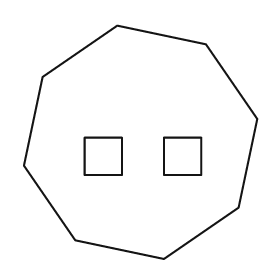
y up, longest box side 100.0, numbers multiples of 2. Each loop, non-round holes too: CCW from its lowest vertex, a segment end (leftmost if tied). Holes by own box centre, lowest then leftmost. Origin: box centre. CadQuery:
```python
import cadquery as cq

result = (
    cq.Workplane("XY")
    .moveTo(10.0, -50.0)
    .lineTo(42.0, -28.0)
    .lineTo(50.0, 10.0)
    .lineTo(28.0, 42.0)
    .lineTo(-10.0, 50.0)
    .lineTo(-42.0, 28.0)
    .lineTo(-50.0, -10.0)
    .lineTo(-28.0, -42.0)
    .close()
    .moveTo(-24.0, -14.0)
    .lineTo(-8.0, -14.0)
    .lineTo(-8.0, 2.0)
    .lineTo(-24.0, 2.0)
    .close()
    .moveTo(10.0, -14.0)
    .lineTo(26.0, -14.0)
    .lineTo(26.0, 2.0)
    .lineTo(10.0, 2.0)
    .close()
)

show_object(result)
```